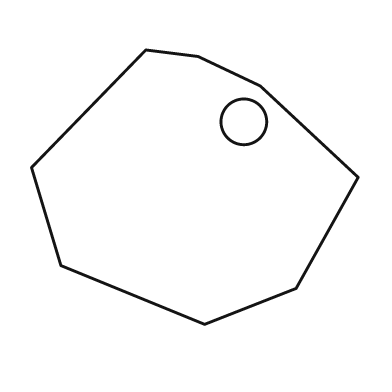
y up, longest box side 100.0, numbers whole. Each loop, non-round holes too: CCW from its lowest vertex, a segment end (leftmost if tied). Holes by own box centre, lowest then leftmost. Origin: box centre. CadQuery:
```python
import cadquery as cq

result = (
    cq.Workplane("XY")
    .moveTo(3.0, -42.0)
    .lineTo(31.0, -31.0)
    .lineTo(50.0, 3.0)
    .lineTo(20.0, 31.0)
    .lineTo(1.0, 40.0)
    .lineTo(-15.0, 42.0)
    .lineTo(-50.0, 6.0)
    .lineTo(-41.0, -24.0)
    .close()
    .moveTo(15.0, 20.0)
    .circle(7.0)
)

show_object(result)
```